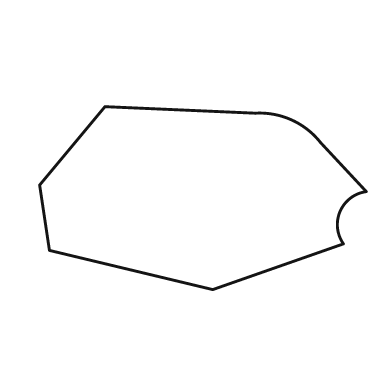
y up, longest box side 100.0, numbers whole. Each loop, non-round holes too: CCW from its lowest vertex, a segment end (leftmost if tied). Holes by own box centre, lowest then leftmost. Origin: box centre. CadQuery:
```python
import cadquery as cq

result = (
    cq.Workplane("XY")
    .moveTo(3.0, -28.0)
    .lineTo(43.0, -14.0)
    .threePointArc((42.0, -4.0), (50.0, 2.0))
    .lineTo(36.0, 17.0)
    .threePointArc((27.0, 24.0), (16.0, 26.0))
    .lineTo(-30.0, 28.0)
    .lineTo(-50.0, 4.0)
    .lineTo(-47.0, -16.0)
    .close()
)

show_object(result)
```